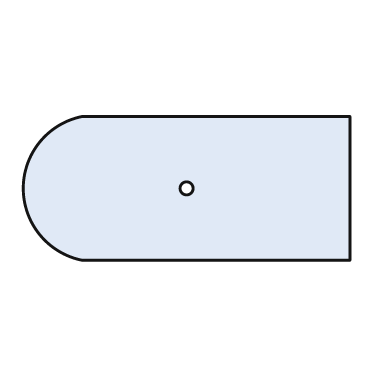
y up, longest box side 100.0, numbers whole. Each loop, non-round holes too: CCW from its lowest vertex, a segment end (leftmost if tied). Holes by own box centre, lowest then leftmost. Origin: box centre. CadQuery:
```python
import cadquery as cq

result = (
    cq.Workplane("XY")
    .moveTo(-32.0, -22.0)
    .lineTo(50.0, -22.0)
    .lineTo(50.0, 22.0)
    .lineTo(-32.0, 22.0)
    .threePointArc((-50.0, 0.0), (-32.0, -22.0))
    .close()
    .moveTo(0.0, 0.0)
    .circle(2.0)
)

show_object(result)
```